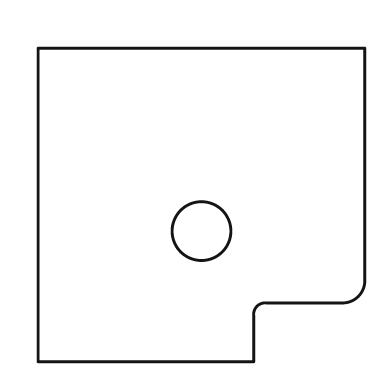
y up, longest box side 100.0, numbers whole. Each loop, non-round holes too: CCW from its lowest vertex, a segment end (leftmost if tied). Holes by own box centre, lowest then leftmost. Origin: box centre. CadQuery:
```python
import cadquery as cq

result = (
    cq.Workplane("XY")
    .moveTo(-50.0, -48.0)
    .lineTo(16.0, -48.0)
    .lineTo(16.0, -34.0)
    .threePointArc((17.0, -31.0), (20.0, -30.0))
    .lineTo(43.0, -30.0)
    .threePointArc((48.0, -28.0), (50.0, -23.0))
    .lineTo(50.0, 48.0)
    .lineTo(-50.0, 48.0)
    .close()
    .moveTo(0.0, -8.0)
    .circle(9.0)
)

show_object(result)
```